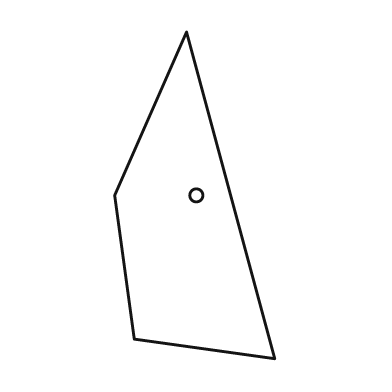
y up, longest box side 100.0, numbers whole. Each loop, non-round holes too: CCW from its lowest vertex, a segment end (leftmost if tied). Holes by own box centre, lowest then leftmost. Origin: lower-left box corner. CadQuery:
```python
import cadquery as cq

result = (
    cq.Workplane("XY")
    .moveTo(49.0, 0.0)
    .lineTo(22.0, 100.0)
    .lineTo(0.0, 50.0)
    .lineTo(6.0, 6.0)
    .close()
    .moveTo(25.0, 50.0)
    .circle(2.0)
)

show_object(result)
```